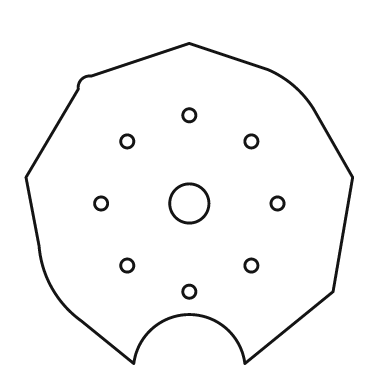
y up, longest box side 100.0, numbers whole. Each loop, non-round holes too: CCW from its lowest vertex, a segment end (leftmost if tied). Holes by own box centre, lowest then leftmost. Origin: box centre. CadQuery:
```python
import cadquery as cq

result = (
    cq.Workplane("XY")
    .moveTo(-17.0, -49.0)
    .threePointArc((0.0, -34.0), (17.0, -49.0))
    .lineTo(44.0, -27.0)
    .lineTo(50.0, 8.0)
    .lineTo(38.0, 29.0)
    .threePointArc((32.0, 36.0), (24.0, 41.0))
    .lineTo(0.0, 49.0)
    .lineTo(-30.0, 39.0)
    .threePointArc((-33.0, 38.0), (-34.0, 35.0))
    .lineTo(-50.0, 8.0)
    .lineTo(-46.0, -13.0)
    .threePointArc((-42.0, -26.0), (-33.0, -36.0))
    .close()
    .moveTo(0.0, -27.0)
    .circle(2.0)
    .moveTo(-19.0, -19.0)
    .circle(2.0)
    .moveTo(19.0, -19.0)
    .circle(2.0)
    .moveTo(-27.0, 0.0)
    .circle(2.0)
    .moveTo(0.0, 0.0)
    .circle(6.0)
    .moveTo(27.0, 0.0)
    .circle(2.0)
    .moveTo(-19.0, 19.0)
    .circle(2.0)
    .moveTo(19.0, 19.0)
    .circle(2.0)
    .moveTo(0.0, 27.0)
    .circle(2.0)
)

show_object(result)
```